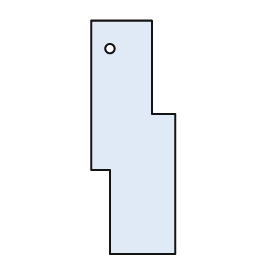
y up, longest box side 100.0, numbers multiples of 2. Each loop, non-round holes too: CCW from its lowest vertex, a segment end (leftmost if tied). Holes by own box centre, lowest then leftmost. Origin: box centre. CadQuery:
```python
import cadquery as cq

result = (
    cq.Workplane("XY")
    .moveTo(-10.0, -50.0)
    .lineTo(18.0, -50.0)
    .lineTo(18.0, 10.0)
    .lineTo(8.0, 10.0)
    .lineTo(8.0, 50.0)
    .lineTo(-18.0, 50.0)
    .lineTo(-18.0, -14.0)
    .lineTo(-10.0, -14.0)
    .close()
    .moveTo(-10.0, 38.0)
    .circle(2.0)
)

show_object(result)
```